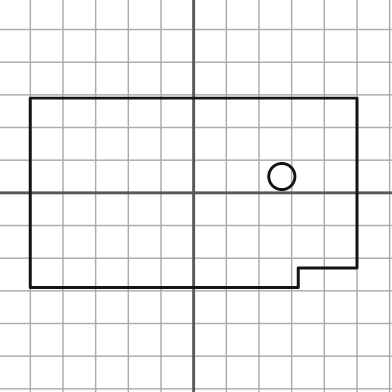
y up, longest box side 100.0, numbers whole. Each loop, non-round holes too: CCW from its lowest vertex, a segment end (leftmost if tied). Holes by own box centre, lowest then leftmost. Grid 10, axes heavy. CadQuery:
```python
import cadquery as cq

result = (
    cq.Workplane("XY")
    .moveTo(-50.0, -29.0)
    .lineTo(32.0, -29.0)
    .lineTo(32.0, -23.0)
    .lineTo(50.0, -23.0)
    .lineTo(50.0, 29.0)
    .lineTo(-50.0, 29.0)
    .close()
    .moveTo(27.0, 5.0)
    .circle(4.0)
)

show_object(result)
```